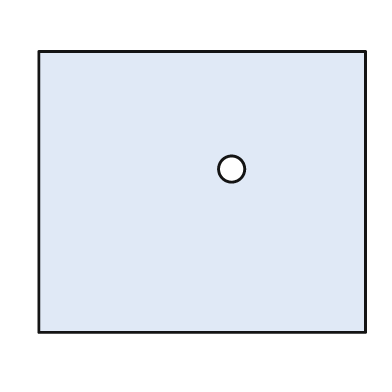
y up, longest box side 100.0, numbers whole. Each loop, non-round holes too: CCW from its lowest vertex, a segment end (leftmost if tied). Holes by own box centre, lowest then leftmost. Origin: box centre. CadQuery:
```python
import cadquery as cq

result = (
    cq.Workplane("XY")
    .moveTo(-50.0, -43.0)
    .lineTo(50.0, -43.0)
    .lineTo(50.0, 43.0)
    .lineTo(-50.0, 43.0)
    .close()
    .moveTo(9.0, 7.0)
    .circle(4.0)
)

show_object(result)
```